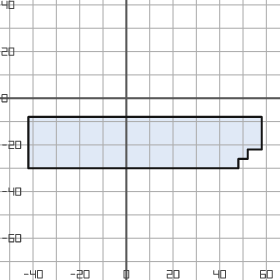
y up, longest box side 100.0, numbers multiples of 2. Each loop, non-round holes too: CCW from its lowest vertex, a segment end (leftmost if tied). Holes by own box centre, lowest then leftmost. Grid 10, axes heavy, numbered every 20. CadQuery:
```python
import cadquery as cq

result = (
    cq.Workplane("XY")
    .moveTo(-42.0, -30.0)
    .lineTo(48.0, -30.0)
    .lineTo(48.0, -26.0)
    .lineTo(52.0, -26.0)
    .lineTo(52.0, -22.0)
    .lineTo(58.0, -22.0)
    .lineTo(58.0, -8.0)
    .lineTo(-42.0, -8.0)
    .close()
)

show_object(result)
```